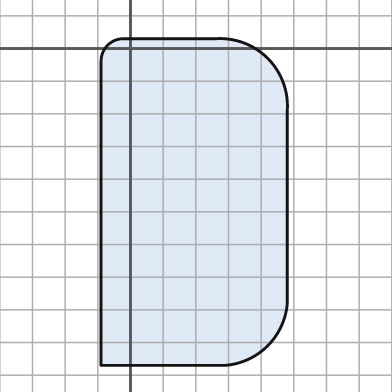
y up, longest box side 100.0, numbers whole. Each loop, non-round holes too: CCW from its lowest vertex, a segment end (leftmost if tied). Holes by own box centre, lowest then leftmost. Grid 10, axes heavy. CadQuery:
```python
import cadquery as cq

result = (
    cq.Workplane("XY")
    .moveTo(-9.0, -97.0)
    .lineTo(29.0, -97.0)
    .threePointArc((42.0, -91.0), (48.0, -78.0))
    .lineTo(48.0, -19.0)
    .threePointArc((42.0, -3.0), (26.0, 3.0))
    .lineTo(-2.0, 3.0)
    .threePointArc((-7.0, 1.0), (-9.0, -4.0))
    .close()
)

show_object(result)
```